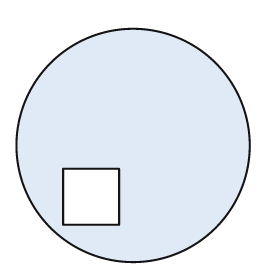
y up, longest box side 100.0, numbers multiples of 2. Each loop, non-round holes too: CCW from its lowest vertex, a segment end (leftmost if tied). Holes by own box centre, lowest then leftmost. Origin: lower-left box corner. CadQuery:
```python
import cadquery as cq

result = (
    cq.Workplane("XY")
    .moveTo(50.0, 50.0)
    .circle(50.0)
    .moveTo(20.0, 16.0)
    .lineTo(44.0, 16.0)
    .lineTo(44.0, 40.0)
    .lineTo(20.0, 40.0)
    .close()
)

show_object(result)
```